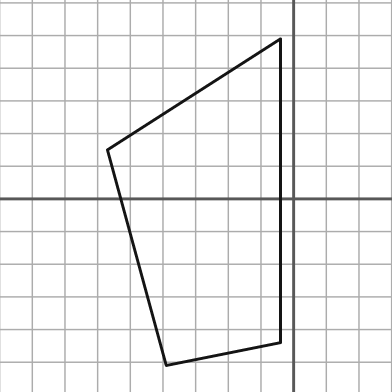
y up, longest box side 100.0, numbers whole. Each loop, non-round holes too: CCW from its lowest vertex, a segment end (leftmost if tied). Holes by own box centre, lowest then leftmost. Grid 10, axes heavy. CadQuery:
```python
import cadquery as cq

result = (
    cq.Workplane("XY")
    .moveTo(-39.0, -51.0)
    .lineTo(-4.0, -44.0)
    .lineTo(-4.0, 49.0)
    .lineTo(-57.0, 15.0)
    .close()
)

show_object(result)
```